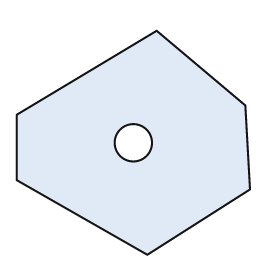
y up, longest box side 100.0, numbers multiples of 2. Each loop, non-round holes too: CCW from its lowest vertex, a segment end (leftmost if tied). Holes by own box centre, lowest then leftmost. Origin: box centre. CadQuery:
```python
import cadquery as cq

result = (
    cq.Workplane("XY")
    .moveTo(6.0, -48.0)
    .lineTo(50.0, -20.0)
    .lineTo(48.0, 16.0)
    .lineTo(10.0, 48.0)
    .lineTo(-50.0, 12.0)
    .lineTo(-50.0, -16.0)
    .close()
    .moveTo(0.0, 0.0)
    .circle(8.0)
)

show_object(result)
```